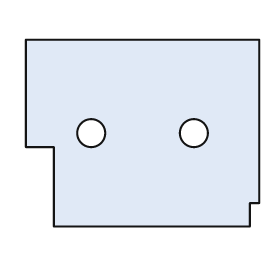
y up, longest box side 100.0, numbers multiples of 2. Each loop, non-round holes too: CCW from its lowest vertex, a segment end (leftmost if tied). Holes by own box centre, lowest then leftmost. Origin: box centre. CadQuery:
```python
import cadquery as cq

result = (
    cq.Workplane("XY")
    .moveTo(-38.0, -40.0)
    .lineTo(46.0, -40.0)
    .lineTo(46.0, -30.0)
    .lineTo(50.0, -30.0)
    .lineTo(50.0, 40.0)
    .lineTo(-50.0, 40.0)
    .lineTo(-50.0, -6.0)
    .lineTo(-38.0, -6.0)
    .close()
    .moveTo(-22.0, 0.0)
    .circle(6.0)
    .moveTo(22.0, 0.0)
    .circle(6.0)
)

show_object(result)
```